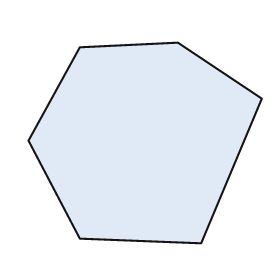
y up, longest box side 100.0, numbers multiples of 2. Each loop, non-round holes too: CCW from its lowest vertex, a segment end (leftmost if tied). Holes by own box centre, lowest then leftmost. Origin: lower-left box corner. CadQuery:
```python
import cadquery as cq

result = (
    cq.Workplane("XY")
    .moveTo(74.0, 0.0)
    .lineTo(100.0, 62.0)
    .lineTo(64.0, 86.0)
    .lineTo(22.0, 84.0)
    .lineTo(0.0, 44.0)
    .lineTo(22.0, 2.0)
    .close()
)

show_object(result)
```